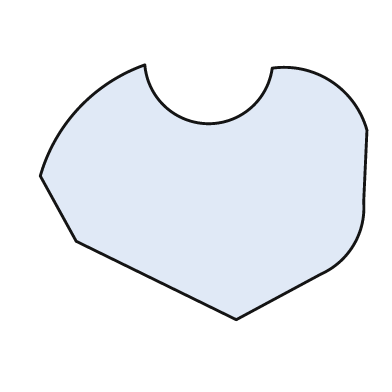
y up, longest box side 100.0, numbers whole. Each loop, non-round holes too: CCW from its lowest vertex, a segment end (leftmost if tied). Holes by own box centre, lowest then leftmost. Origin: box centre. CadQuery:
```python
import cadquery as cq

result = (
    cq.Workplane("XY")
    .moveTo(10.0, -39.0)
    .lineTo(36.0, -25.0)
    .threePointArc((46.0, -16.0), (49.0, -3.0))
    .lineTo(50.0, 19.0)
    .threePointArc((39.0, 34.0), (21.0, 38.0))
    .threePointArc((1.0, 21.0), (-18.0, 39.0))
    .threePointArc((-38.0, 26.0), (-50.0, 5.0))
    .lineTo(-39.0, -15.0)
    .close()
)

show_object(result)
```